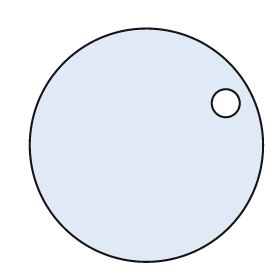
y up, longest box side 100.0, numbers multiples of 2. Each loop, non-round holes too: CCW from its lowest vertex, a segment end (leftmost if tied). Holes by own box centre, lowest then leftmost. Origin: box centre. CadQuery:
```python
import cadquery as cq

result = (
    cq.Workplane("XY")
    .moveTo(0.0, 0.0)
    .circle(50.0)
    .moveTo(34.0, 18.0)
    .circle(6.0)
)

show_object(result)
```